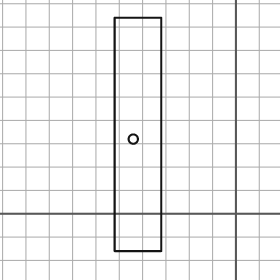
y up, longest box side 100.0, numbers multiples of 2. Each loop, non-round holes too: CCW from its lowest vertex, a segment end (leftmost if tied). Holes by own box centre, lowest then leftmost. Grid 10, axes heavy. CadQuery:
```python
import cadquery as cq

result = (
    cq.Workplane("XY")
    .moveTo(-52.0, -16.0)
    .lineTo(-32.0, -16.0)
    .lineTo(-32.0, 84.0)
    .lineTo(-52.0, 84.0)
    .close()
    .moveTo(-44.0, 32.0)
    .circle(2.0)
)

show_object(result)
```